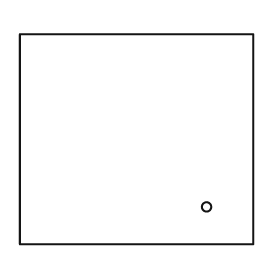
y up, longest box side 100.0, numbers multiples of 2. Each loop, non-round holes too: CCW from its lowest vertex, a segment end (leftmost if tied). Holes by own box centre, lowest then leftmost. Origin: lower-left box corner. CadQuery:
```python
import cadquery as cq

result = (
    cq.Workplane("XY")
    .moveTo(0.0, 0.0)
    .lineTo(100.0, 0.0)
    .lineTo(100.0, 90.0)
    .lineTo(0.0, 90.0)
    .close()
    .moveTo(80.0, 16.0)
    .circle(2.0)
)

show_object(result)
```